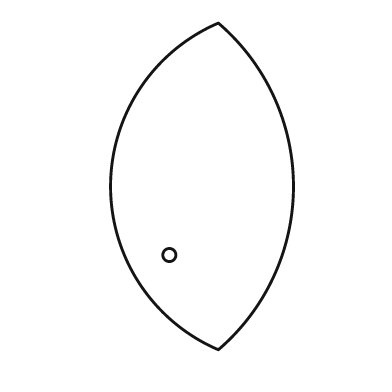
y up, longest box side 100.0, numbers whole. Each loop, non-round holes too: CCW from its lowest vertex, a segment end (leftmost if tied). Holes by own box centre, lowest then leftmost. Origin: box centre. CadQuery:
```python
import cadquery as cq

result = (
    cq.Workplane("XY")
    .moveTo(5.0, -50.0)
    .threePointArc((28.0, 0.0), (5.0, 50.0))
    .threePointArc((-28.0, 0.0), (5.0, -50.0))
    .close()
    .moveTo(-10.0, -21.0)
    .circle(2.0)
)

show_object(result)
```